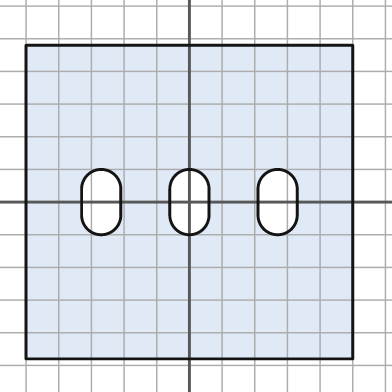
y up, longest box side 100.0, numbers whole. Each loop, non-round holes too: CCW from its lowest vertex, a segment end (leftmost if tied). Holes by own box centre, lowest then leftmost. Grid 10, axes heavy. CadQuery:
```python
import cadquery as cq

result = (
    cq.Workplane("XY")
    .moveTo(-50.0, -48.0)
    .lineTo(50.0, -48.0)
    .lineTo(50.0, 48.0)
    .lineTo(-50.0, 48.0)
    .close()
    .moveTo(-33.0, -4.0)
    .threePointArc((-27.0, -10.0), (-21.0, -4.0))
    .lineTo(-21.0, 4.0)
    .threePointArc((-27.0, 10.0), (-33.0, 4.0))
    .close()
    .moveTo(-6.0, -4.0)
    .threePointArc((0.0, -10.0), (6.0, -4.0))
    .lineTo(6.0, 4.0)
    .threePointArc((0.0, 10.0), (-6.0, 4.0))
    .close()
    .moveTo(21.0, -4.0)
    .threePointArc((27.0, -10.0), (33.0, -4.0))
    .lineTo(33.0, 4.0)
    .threePointArc((27.0, 10.0), (21.0, 4.0))
    .close()
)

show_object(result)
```